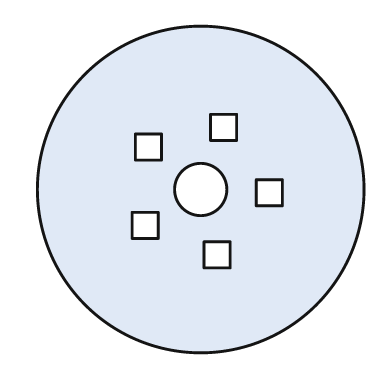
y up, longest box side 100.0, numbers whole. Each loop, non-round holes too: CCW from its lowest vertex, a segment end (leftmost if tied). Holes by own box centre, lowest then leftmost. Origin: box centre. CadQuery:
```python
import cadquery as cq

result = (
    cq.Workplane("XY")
    .moveTo(0.0, 0.0)
    .circle(50.0)
    .moveTo(1.0, -24.0)
    .lineTo(9.0, -24.0)
    .lineTo(9.0, -16.0)
    .lineTo(1.0, -16.0)
    .close()
    .moveTo(-21.0, -15.0)
    .lineTo(-13.0, -15.0)
    .lineTo(-13.0, -7.0)
    .lineTo(-21.0, -7.0)
    .close()
    .moveTo(17.0, -5.0)
    .lineTo(25.0, -5.0)
    .lineTo(25.0, 3.0)
    .lineTo(17.0, 3.0)
    .close()
    .moveTo(0.0, 0.0)
    .circle(8.0)
    .moveTo(-20.0, 9.0)
    .lineTo(-12.0, 9.0)
    .lineTo(-12.0, 17.0)
    .lineTo(-20.0, 17.0)
    .close()
    .moveTo(3.0, 15.0)
    .lineTo(11.0, 15.0)
    .lineTo(11.0, 23.0)
    .lineTo(3.0, 23.0)
    .close()
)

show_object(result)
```